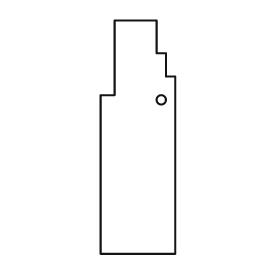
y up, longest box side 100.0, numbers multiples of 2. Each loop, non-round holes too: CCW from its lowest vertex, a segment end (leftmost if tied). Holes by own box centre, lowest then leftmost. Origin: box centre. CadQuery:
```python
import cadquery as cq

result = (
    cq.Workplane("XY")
    .moveTo(-16.0, -50.0)
    .lineTo(16.0, -50.0)
    .lineTo(16.0, 26.0)
    .lineTo(12.0, 26.0)
    .lineTo(12.0, 36.0)
    .lineTo(8.0, 36.0)
    .lineTo(8.0, 50.0)
    .lineTo(-10.0, 50.0)
    .lineTo(-10.0, 18.0)
    .lineTo(-16.0, 18.0)
    .close()
    .moveTo(10.0, 16.0)
    .circle(2.0)
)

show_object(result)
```